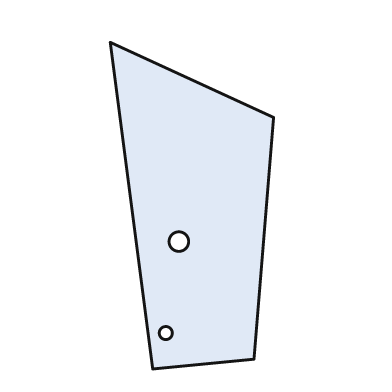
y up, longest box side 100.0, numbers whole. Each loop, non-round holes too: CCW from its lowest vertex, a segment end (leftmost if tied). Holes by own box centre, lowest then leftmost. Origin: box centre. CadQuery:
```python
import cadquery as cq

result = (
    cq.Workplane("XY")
    .moveTo(-12.0, -50.0)
    .lineTo(19.0, -47.0)
    .lineTo(25.0, 27.0)
    .lineTo(-25.0, 50.0)
    .close()
    .moveTo(-8.0, -39.0)
    .circle(2.0)
    .moveTo(-4.0, -11.0)
    .circle(3.0)
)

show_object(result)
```